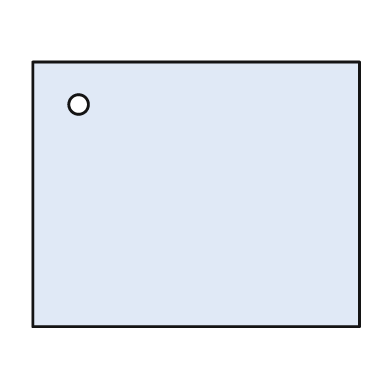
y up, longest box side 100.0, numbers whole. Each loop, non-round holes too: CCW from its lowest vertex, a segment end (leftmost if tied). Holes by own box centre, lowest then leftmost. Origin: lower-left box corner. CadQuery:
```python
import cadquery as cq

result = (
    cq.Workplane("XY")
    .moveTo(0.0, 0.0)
    .lineTo(100.0, 0.0)
    .lineTo(100.0, 81.0)
    .lineTo(0.0, 81.0)
    .close()
    .moveTo(14.0, 68.0)
    .circle(3.0)
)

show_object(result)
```